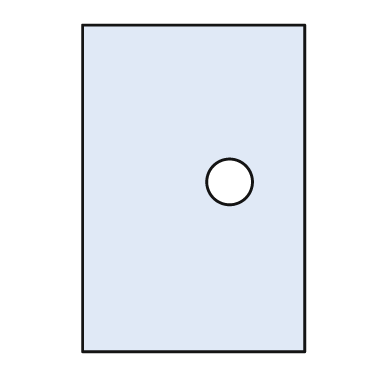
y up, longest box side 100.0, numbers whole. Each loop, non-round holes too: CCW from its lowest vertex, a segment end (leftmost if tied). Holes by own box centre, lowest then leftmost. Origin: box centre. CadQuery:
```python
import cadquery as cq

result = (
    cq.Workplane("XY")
    .moveTo(-34.0, -50.0)
    .lineTo(34.0, -50.0)
    .lineTo(34.0, 50.0)
    .lineTo(-34.0, 50.0)
    .close()
    .moveTo(11.0, 2.0)
    .circle(7.0)
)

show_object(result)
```